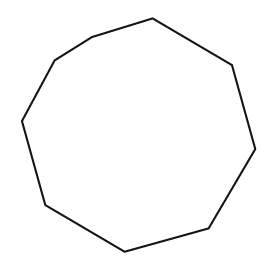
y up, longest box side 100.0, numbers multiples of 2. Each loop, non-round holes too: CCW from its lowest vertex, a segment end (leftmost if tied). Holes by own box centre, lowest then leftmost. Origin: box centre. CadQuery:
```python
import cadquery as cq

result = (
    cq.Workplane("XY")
    .moveTo(-6.0, -50.0)
    .lineTo(30.0, -40.0)
    .lineTo(50.0, -6.0)
    .lineTo(40.0, 30.0)
    .lineTo(6.0, 50.0)
    .lineTo(-20.0, 42.0)
    .lineTo(-36.0, 32.0)
    .lineTo(-50.0, 6.0)
    .lineTo(-40.0, -30.0)
    .close()
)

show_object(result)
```